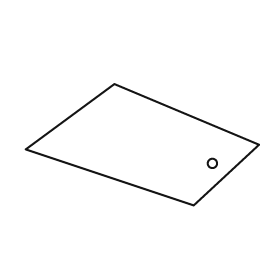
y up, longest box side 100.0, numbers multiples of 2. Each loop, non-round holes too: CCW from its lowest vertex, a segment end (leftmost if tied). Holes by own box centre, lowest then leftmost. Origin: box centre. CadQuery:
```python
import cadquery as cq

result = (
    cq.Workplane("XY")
    .moveTo(22.0, -26.0)
    .lineTo(50.0, 0.0)
    .lineTo(-12.0, 26.0)
    .lineTo(-50.0, -2.0)
    .close()
    .moveTo(30.0, -8.0)
    .circle(2.0)
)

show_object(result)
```